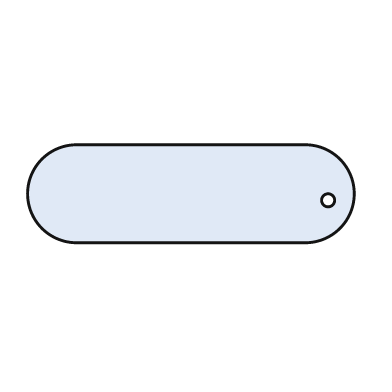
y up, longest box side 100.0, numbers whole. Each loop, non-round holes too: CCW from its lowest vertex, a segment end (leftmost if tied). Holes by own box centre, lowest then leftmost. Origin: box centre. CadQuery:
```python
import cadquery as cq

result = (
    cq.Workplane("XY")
    .moveTo(-35.0, -15.0)
    .lineTo(35.0, -15.0)
    .threePointArc((50.0, 0.0), (35.0, 15.0))
    .lineTo(-35.0, 15.0)
    .threePointArc((-50.0, 0.0), (-35.0, -15.0))
    .close()
    .moveTo(42.0, -2.0)
    .circle(2.0)
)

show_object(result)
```